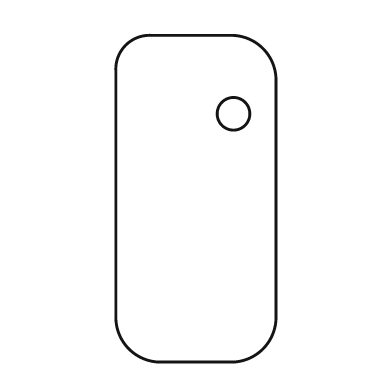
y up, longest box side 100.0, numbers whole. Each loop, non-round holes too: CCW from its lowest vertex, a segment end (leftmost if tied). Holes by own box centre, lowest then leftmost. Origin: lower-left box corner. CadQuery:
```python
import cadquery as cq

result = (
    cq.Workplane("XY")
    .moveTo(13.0, 0.0)
    .lineTo(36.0, 0.0)
    .threePointArc((45.0, 4.0), (49.0, 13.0))
    .lineTo(49.0, 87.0)
    .threePointArc((45.0, 96.0), (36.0, 100.0))
    .lineTo(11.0, 100.0)
    .threePointArc((3.0, 97.0), (0.0, 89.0))
    .lineTo(0.0, 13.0)
    .threePointArc((4.0, 4.0), (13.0, 0.0))
    .close()
    .moveTo(36.0, 76.0)
    .circle(5.0)
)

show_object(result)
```